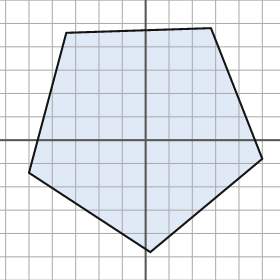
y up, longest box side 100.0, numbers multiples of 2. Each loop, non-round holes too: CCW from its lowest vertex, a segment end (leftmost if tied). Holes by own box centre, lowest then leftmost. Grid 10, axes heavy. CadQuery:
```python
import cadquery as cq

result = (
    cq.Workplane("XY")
    .moveTo(2.0, -48.0)
    .lineTo(50.0, -8.0)
    .lineTo(28.0, 48.0)
    .lineTo(-34.0, 46.0)
    .lineTo(-50.0, -14.0)
    .close()
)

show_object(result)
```